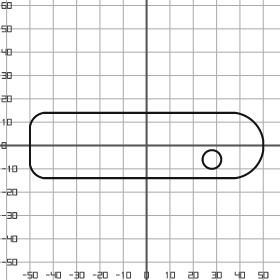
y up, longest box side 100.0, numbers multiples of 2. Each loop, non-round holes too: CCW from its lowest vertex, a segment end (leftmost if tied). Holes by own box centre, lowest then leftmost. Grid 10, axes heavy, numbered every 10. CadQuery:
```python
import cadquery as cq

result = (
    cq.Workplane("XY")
    .moveTo(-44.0, -14.0)
    .lineTo(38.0, -14.0)
    .threePointArc((46.0, -10.0), (50.0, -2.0))
    .lineTo(50.0, 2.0)
    .threePointArc((46.0, 10.0), (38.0, 14.0))
    .lineTo(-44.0, 14.0)
    .threePointArc((-48.0, 12.0), (-50.0, 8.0))
    .lineTo(-50.0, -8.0)
    .threePointArc((-48.0, -12.0), (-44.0, -14.0))
    .close()
    .moveTo(28.0, -6.0)
    .circle(4.0)
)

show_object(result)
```